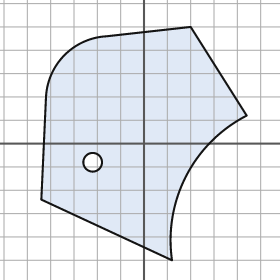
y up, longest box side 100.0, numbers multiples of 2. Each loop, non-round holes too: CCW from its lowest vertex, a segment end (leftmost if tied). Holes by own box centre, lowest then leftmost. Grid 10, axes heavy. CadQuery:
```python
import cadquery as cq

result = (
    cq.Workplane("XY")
    .moveTo(12.0, -50.0)
    .threePointArc((18.0, -14.0), (44.0, 12.0))
    .lineTo(20.0, 50.0)
    .lineTo(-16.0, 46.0)
    .threePointArc((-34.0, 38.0), (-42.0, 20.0))
    .lineTo(-44.0, -24.0)
    .close()
    .moveTo(-22.0, -8.0)
    .circle(4.0)
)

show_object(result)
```